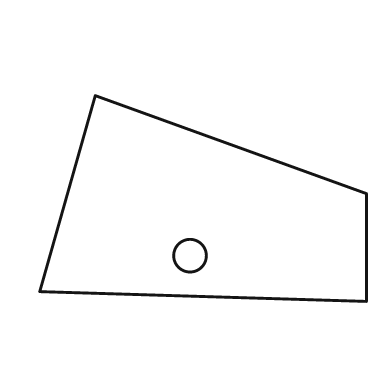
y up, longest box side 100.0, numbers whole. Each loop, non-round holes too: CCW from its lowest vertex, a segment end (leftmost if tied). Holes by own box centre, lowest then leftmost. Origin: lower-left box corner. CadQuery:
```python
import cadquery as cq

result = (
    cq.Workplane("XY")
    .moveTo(100.0, 0.0)
    .lineTo(100.0, 33.0)
    .lineTo(17.0, 63.0)
    .lineTo(0.0, 3.0)
    .close()
    .moveTo(46.0, 14.0)
    .circle(5.0)
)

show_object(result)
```